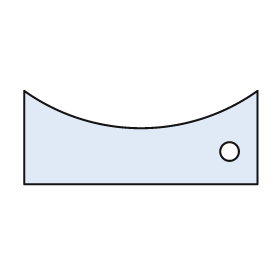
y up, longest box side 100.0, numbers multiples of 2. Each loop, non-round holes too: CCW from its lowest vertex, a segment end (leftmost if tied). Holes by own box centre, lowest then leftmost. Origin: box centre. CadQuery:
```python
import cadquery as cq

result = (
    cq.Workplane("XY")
    .moveTo(-50.0, -20.0)
    .lineTo(50.0, -20.0)
    .lineTo(50.0, 20.0)
    .threePointArc((0.0, 4.0), (-50.0, 20.0))
    .close()
    .moveTo(38.0, -6.0)
    .circle(4.0)
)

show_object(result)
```